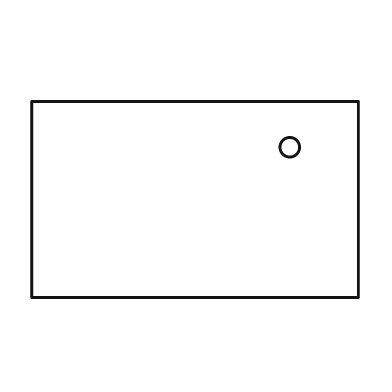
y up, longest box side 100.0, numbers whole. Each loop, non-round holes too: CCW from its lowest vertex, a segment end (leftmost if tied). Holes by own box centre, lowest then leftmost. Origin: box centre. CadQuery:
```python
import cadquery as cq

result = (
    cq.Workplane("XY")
    .moveTo(-50.0, -30.0)
    .lineTo(50.0, -30.0)
    .lineTo(50.0, 30.0)
    .lineTo(-50.0, 30.0)
    .close()
    .moveTo(29.0, 16.0)
    .circle(3.0)
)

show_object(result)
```